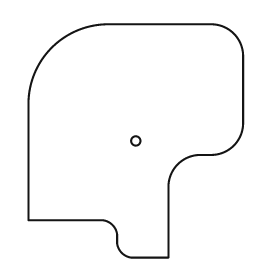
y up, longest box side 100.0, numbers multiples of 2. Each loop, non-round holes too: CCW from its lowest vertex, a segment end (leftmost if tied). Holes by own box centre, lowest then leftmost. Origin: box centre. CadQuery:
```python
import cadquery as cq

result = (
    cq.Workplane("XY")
    .moveTo(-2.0, -50.0)
    .lineTo(14.0, -50.0)
    .lineTo(14.0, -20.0)
    .threePointArc((18.0, -10.0), (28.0, -6.0))
    .lineTo(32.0, -6.0)
    .threePointArc((42.0, -2.0), (46.0, 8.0))
    .lineTo(46.0, 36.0)
    .threePointArc((42.0, 46.0), (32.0, 50.0))
    .lineTo(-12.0, 50.0)
    .threePointArc((-36.0, 40.0), (-46.0, 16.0))
    .lineTo(-46.0, -34.0)
    .lineTo(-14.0, -34.0)
    .threePointArc((-10.0, -36.0), (-8.0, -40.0))
    .lineTo(-8.0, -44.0)
    .threePointArc((-6.0, -48.0), (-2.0, -50.0))
    .close()
    .moveTo(0.0, 0.0)
    .circle(2.0)
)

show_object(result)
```